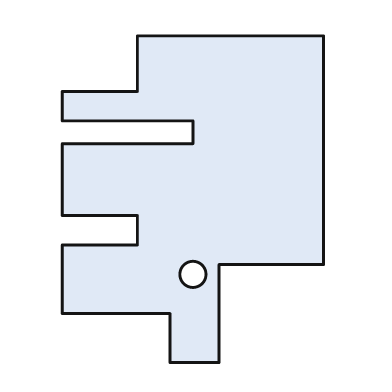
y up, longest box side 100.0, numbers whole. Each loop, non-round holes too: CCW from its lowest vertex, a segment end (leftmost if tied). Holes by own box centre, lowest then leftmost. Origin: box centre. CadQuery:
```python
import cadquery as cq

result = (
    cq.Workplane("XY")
    .moveTo(-7.0, -50.0)
    .lineTo(8.0, -50.0)
    .lineTo(8.0, -20.0)
    .lineTo(40.0, -20.0)
    .lineTo(40.0, 50.0)
    .lineTo(-17.0, 50.0)
    .lineTo(-17.0, 33.0)
    .lineTo(-40.0, 33.0)
    .lineTo(-40.0, 24.0)
    .lineTo(0.0, 24.0)
    .lineTo(0.0, 17.0)
    .lineTo(-40.0, 17.0)
    .lineTo(-40.0, -5.0)
    .lineTo(-17.0, -5.0)
    .lineTo(-17.0, -14.0)
    .lineTo(-40.0, -14.0)
    .lineTo(-40.0, -35.0)
    .lineTo(-7.0, -35.0)
    .close()
    .moveTo(0.0, -23.0)
    .circle(4.0)
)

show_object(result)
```